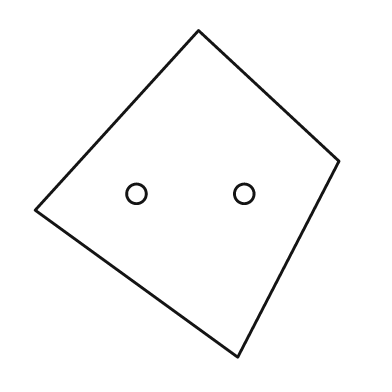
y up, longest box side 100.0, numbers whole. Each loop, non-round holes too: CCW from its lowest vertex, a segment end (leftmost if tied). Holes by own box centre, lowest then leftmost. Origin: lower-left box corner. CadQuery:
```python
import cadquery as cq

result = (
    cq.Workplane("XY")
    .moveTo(62.0, 0.0)
    .lineTo(93.0, 60.0)
    .lineTo(50.0, 100.0)
    .lineTo(0.0, 45.0)
    .close()
    .moveTo(31.0, 50.0)
    .circle(3.0)
    .moveTo(64.0, 50.0)
    .circle(3.0)
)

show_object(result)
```